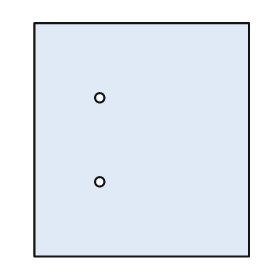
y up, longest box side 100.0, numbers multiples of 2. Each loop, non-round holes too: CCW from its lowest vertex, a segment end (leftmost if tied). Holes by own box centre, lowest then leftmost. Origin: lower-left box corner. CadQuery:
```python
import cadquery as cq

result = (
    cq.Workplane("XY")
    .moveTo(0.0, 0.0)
    .lineTo(92.0, 0.0)
    .lineTo(92.0, 100.0)
    .lineTo(0.0, 100.0)
    .close()
    .moveTo(28.0, 32.0)
    .circle(2.0)
    .moveTo(28.0, 68.0)
    .circle(2.0)
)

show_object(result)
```